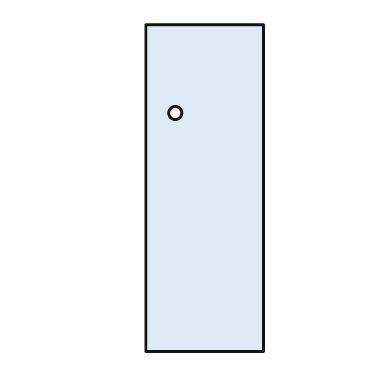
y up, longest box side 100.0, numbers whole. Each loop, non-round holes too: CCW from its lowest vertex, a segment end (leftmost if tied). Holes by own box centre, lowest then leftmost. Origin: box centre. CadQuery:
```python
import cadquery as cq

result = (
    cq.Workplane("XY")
    .moveTo(-18.0, -50.0)
    .lineTo(18.0, -50.0)
    .lineTo(18.0, 50.0)
    .lineTo(-18.0, 50.0)
    .close()
    .moveTo(-9.0, 23.0)
    .circle(2.0)
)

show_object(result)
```